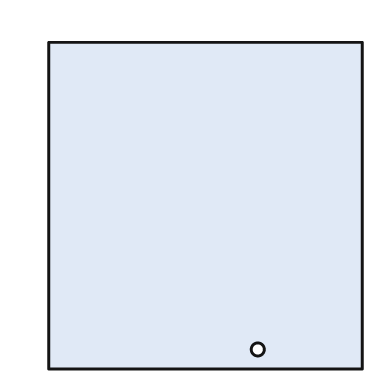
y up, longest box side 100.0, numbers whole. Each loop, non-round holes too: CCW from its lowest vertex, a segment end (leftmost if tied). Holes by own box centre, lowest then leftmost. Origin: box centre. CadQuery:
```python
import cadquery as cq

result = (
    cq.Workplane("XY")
    .moveTo(-48.0, -50.0)
    .lineTo(48.0, -50.0)
    .lineTo(48.0, 50.0)
    .lineTo(-48.0, 50.0)
    .close()
    .moveTo(16.0, -44.0)
    .circle(2.0)
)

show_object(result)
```